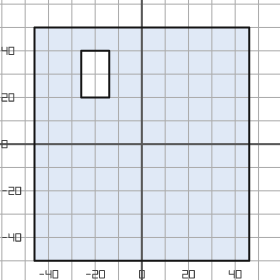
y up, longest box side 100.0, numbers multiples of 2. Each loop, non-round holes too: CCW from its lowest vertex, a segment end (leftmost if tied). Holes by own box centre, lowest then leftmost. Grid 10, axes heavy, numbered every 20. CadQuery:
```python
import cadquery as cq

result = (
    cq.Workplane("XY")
    .moveTo(-46.0, -50.0)
    .lineTo(46.0, -50.0)
    .lineTo(46.0, 50.0)
    .lineTo(-46.0, 50.0)
    .close()
    .moveTo(-26.0, 20.0)
    .lineTo(-14.0, 20.0)
    .lineTo(-14.0, 40.0)
    .lineTo(-26.0, 40.0)
    .close()
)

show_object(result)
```